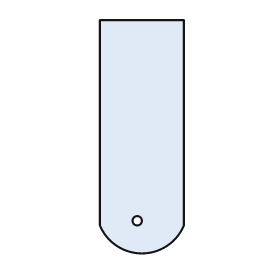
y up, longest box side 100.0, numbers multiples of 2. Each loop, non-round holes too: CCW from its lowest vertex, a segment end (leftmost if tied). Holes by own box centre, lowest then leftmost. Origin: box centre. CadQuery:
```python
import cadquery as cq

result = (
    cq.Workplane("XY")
    .moveTo(-18.0, -38.0)
    .threePointArc((0.0, -50.0), (18.0, -38.0))
    .lineTo(18.0, 50.0)
    .lineTo(-18.0, 50.0)
    .close()
    .moveTo(-2.0, -36.0)
    .circle(2.0)
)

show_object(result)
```